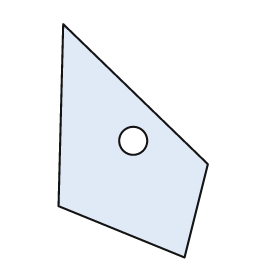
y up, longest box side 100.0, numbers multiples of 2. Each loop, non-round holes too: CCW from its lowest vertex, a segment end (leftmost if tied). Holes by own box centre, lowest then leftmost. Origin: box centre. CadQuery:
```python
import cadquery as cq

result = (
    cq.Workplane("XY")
    .moveTo(22.0, -50.0)
    .lineTo(32.0, -10.0)
    .lineTo(-30.0, 50.0)
    .lineTo(-32.0, -28.0)
    .close()
    .moveTo(0.0, 0.0)
    .circle(6.0)
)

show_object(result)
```